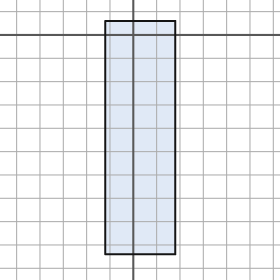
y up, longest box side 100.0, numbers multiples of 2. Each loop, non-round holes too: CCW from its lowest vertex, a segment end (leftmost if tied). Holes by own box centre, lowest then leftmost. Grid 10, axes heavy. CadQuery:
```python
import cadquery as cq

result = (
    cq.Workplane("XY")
    .moveTo(-12.0, -94.0)
    .lineTo(18.0, -94.0)
    .lineTo(18.0, 6.0)
    .lineTo(-12.0, 6.0)
    .close()
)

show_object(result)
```